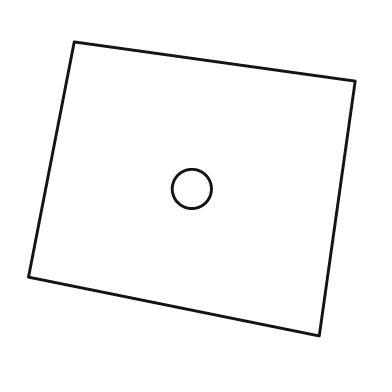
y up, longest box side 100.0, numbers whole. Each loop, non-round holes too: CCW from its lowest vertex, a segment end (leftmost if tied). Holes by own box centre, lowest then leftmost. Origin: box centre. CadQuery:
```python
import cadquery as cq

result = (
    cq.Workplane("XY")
    .moveTo(39.0, -45.0)
    .lineTo(50.0, 33.0)
    .lineTo(-36.0, 45.0)
    .lineTo(-50.0, -27.0)
    .close()
    .moveTo(0.0, 0.0)
    .circle(6.0)
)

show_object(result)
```